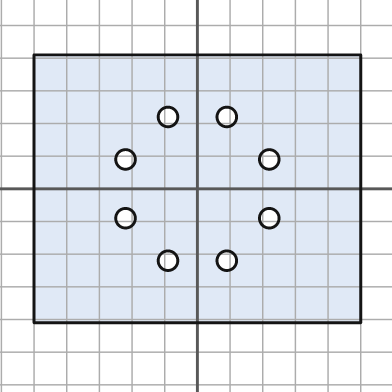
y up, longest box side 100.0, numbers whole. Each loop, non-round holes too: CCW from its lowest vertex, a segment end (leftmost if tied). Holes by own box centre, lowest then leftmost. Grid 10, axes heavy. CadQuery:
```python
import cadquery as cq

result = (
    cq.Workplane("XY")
    .moveTo(-50.0, -41.0)
    .lineTo(50.0, -41.0)
    .lineTo(50.0, 41.0)
    .lineTo(-50.0, 41.0)
    .close()
    .moveTo(-9.0, -22.0)
    .circle(3.0)
    .moveTo(9.0, -22.0)
    .circle(3.0)
    .moveTo(-22.0, -9.0)
    .circle(3.0)
    .moveTo(22.0, -9.0)
    .circle(3.0)
    .moveTo(-22.0, 9.0)
    .circle(3.0)
    .moveTo(22.0, 9.0)
    .circle(3.0)
    .moveTo(-9.0, 22.0)
    .circle(3.0)
    .moveTo(9.0, 22.0)
    .circle(3.0)
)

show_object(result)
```